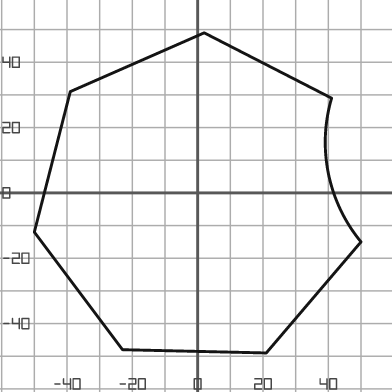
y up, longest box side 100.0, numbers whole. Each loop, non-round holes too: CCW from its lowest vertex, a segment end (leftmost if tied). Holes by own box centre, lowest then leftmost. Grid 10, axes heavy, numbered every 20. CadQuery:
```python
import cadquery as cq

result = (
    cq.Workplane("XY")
    .moveTo(21.0, -49.0)
    .lineTo(50.0, -15.0)
    .threePointArc((40.0, 6.0), (41.0, 29.0))
    .lineTo(2.0, 49.0)
    .lineTo(-39.0, 31.0)
    .lineTo(-50.0, -12.0)
    .lineTo(-23.0, -48.0)
    .close()
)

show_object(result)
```